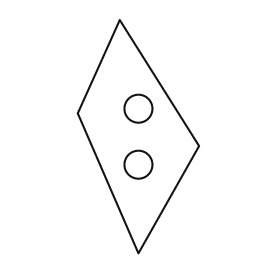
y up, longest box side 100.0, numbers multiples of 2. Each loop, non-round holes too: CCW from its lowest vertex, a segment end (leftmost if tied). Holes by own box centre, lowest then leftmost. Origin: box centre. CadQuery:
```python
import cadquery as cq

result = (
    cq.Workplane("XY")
    .moveTo(0.0, -50.0)
    .lineTo(26.0, -4.0)
    .lineTo(-8.0, 50.0)
    .lineTo(-26.0, 10.0)
    .close()
    .moveTo(0.0, -12.0)
    .circle(6.0)
    .moveTo(0.0, 12.0)
    .circle(6.0)
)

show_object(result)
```